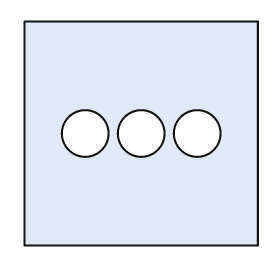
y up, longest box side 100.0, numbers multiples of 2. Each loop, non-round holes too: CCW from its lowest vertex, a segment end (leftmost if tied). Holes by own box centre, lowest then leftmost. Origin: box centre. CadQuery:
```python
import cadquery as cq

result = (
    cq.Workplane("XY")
    .moveTo(-50.0, -48.0)
    .lineTo(50.0, -48.0)
    .lineTo(50.0, 48.0)
    .lineTo(-50.0, 48.0)
    .close()
    .moveTo(-24.0, 0.0)
    .circle(10.0)
    .moveTo(0.0, 0.0)
    .circle(10.0)
    .moveTo(24.0, 0.0)
    .circle(10.0)
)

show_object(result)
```